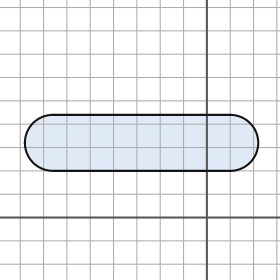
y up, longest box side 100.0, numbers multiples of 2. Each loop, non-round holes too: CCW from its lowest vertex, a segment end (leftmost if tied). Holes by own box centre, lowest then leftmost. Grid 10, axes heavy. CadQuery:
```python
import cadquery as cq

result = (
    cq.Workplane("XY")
    .moveTo(-66.0, 20.0)
    .lineTo(10.0, 20.0)
    .threePointArc((22.0, 32.0), (10.0, 44.0))
    .lineTo(-66.0, 44.0)
    .threePointArc((-78.0, 32.0), (-66.0, 20.0))
    .close()
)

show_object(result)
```